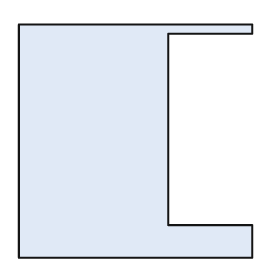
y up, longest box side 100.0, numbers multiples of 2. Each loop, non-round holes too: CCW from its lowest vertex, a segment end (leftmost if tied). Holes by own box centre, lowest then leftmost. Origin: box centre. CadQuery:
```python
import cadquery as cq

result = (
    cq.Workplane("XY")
    .moveTo(-50.0, -50.0)
    .lineTo(50.0, -50.0)
    .lineTo(50.0, -36.0)
    .lineTo(14.0, -36.0)
    .lineTo(14.0, 46.0)
    .lineTo(50.0, 46.0)
    .lineTo(50.0, 50.0)
    .lineTo(-50.0, 50.0)
    .close()
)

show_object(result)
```